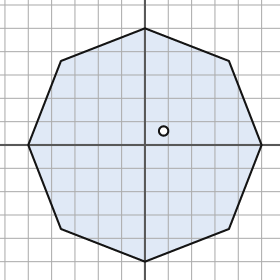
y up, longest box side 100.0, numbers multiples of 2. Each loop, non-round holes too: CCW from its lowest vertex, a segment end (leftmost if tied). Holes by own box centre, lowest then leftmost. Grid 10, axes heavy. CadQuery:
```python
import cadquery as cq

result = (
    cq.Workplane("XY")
    .moveTo(0.0, -50.0)
    .lineTo(36.0, -36.0)
    .lineTo(50.0, 0.0)
    .lineTo(36.0, 36.0)
    .lineTo(0.0, 50.0)
    .lineTo(-36.0, 36.0)
    .lineTo(-50.0, 0.0)
    .lineTo(-36.0, -36.0)
    .close()
    .moveTo(8.0, 6.0)
    .circle(2.0)
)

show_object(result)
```